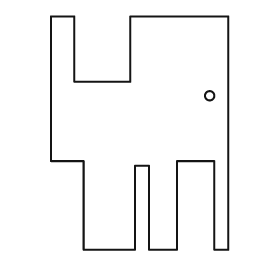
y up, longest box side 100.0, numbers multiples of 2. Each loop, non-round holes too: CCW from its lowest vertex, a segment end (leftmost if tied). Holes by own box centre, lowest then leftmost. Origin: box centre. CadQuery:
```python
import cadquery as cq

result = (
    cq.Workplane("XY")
    .moveTo(-24.0, -50.0)
    .lineTo(-2.0, -50.0)
    .lineTo(-2.0, -14.0)
    .lineTo(4.0, -14.0)
    .lineTo(4.0, -50.0)
    .lineTo(16.0, -50.0)
    .lineTo(16.0, -12.0)
    .lineTo(32.0, -12.0)
    .lineTo(32.0, -50.0)
    .lineTo(38.0, -50.0)
    .lineTo(38.0, 50.0)
    .lineTo(-4.0, 50.0)
    .lineTo(-4.0, 22.0)
    .lineTo(-28.0, 22.0)
    .lineTo(-28.0, 50.0)
    .lineTo(-38.0, 50.0)
    .lineTo(-38.0, -12.0)
    .lineTo(-24.0, -12.0)
    .close()
    .moveTo(30.0, 16.0)
    .circle(2.0)
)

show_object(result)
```